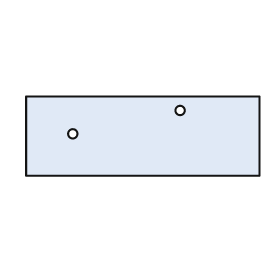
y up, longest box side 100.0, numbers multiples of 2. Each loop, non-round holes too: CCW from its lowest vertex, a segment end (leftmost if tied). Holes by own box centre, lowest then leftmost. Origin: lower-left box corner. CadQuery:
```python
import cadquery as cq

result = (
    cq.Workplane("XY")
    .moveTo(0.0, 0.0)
    .lineTo(100.0, 0.0)
    .lineTo(100.0, 34.0)
    .lineTo(0.0, 34.0)
    .close()
    .moveTo(20.0, 18.0)
    .circle(2.0)
    .moveTo(66.0, 28.0)
    .circle(2.0)
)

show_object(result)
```